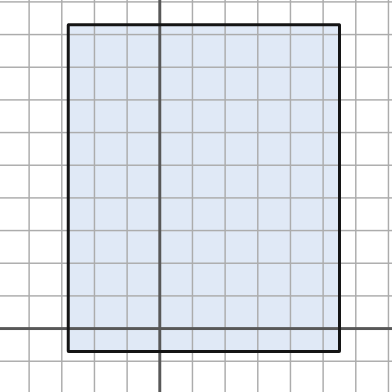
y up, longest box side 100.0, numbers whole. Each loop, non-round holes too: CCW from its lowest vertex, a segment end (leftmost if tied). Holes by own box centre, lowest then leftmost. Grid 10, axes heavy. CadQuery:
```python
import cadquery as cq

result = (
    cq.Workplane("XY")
    .moveTo(-28.0, -7.0)
    .lineTo(55.0, -7.0)
    .lineTo(55.0, 93.0)
    .lineTo(-28.0, 93.0)
    .close()
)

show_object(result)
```